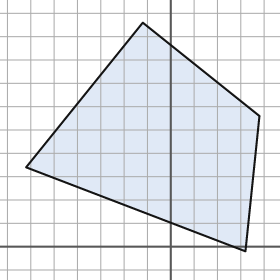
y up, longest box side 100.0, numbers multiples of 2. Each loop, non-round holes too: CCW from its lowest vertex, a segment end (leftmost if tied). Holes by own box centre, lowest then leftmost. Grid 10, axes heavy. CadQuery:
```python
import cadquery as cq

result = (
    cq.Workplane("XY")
    .moveTo(32.0, -2.0)
    .lineTo(38.0, 56.0)
    .lineTo(-12.0, 96.0)
    .lineTo(-62.0, 34.0)
    .close()
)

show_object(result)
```